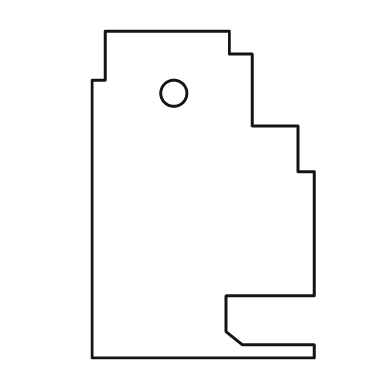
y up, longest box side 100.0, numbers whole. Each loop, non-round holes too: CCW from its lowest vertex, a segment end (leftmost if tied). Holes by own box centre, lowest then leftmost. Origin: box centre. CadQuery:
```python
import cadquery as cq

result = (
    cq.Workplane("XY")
    .moveTo(-34.0, -50.0)
    .lineTo(34.0, -50.0)
    .lineTo(34.0, -46.0)
    .lineTo(12.0, -46.0)
    .lineTo(7.0, -42.0)
    .lineTo(7.0, -31.0)
    .lineTo(34.0, -31.0)
    .lineTo(34.0, 7.0)
    .lineTo(29.0, 7.0)
    .lineTo(29.0, 21.0)
    .lineTo(15.0, 21.0)
    .lineTo(15.0, 43.0)
    .lineTo(8.0, 43.0)
    .lineTo(8.0, 50.0)
    .lineTo(-30.0, 50.0)
    .lineTo(-30.0, 35.0)
    .lineTo(-34.0, 35.0)
    .close()
    .moveTo(-9.0, 31.0)
    .circle(4.0)
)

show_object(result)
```